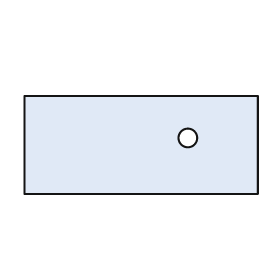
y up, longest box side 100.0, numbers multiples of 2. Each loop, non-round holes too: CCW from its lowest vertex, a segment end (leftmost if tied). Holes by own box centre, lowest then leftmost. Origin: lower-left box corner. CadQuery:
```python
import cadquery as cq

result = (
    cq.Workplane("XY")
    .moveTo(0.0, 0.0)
    .lineTo(100.0, 0.0)
    .lineTo(100.0, 42.0)
    .lineTo(0.0, 42.0)
    .close()
    .moveTo(70.0, 24.0)
    .circle(4.0)
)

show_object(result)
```